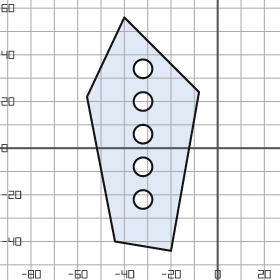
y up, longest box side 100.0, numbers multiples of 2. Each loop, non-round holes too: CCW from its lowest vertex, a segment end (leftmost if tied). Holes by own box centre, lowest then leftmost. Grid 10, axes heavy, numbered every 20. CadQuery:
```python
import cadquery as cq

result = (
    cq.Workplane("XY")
    .moveTo(-20.0, -44.0)
    .lineTo(-8.0, 24.0)
    .lineTo(-40.0, 56.0)
    .lineTo(-56.0, 22.0)
    .lineTo(-44.0, -40.0)
    .close()
    .moveTo(-32.0, -22.0)
    .circle(4.0)
    .moveTo(-32.0, -8.0)
    .circle(4.0)
    .moveTo(-32.0, 6.0)
    .circle(4.0)
    .moveTo(-32.0, 20.0)
    .circle(4.0)
    .moveTo(-32.0, 34.0)
    .circle(4.0)
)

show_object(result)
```